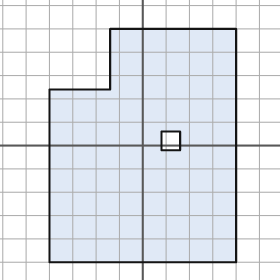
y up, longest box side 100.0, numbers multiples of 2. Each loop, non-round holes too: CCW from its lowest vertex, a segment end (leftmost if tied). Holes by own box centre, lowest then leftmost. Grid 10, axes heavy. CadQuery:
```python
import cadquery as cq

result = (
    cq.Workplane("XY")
    .moveTo(-40.0, -50.0)
    .lineTo(40.0, -50.0)
    .lineTo(40.0, 50.0)
    .lineTo(-14.0, 50.0)
    .lineTo(-14.0, 24.0)
    .lineTo(-40.0, 24.0)
    .close()
    .moveTo(8.0, -2.0)
    .lineTo(16.0, -2.0)
    .lineTo(16.0, 6.0)
    .lineTo(8.0, 6.0)
    .close()
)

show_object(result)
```